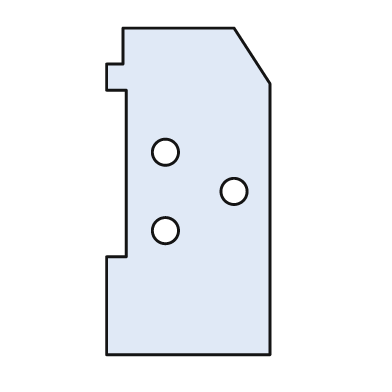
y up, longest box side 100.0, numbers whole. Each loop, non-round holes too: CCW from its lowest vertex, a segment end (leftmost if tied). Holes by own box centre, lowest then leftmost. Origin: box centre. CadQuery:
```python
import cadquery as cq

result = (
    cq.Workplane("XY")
    .moveTo(-25.0, -50.0)
    .lineTo(25.0, -50.0)
    .lineTo(25.0, 33.0)
    .lineTo(14.0, 50.0)
    .lineTo(-20.0, 50.0)
    .lineTo(-20.0, 39.0)
    .lineTo(-25.0, 39.0)
    .lineTo(-25.0, 31.0)
    .lineTo(-19.0, 31.0)
    .lineTo(-19.0, -20.0)
    .lineTo(-25.0, -20.0)
    .close()
    .moveTo(-7.0, -12.0)
    .circle(4.0)
    .moveTo(14.0, 0.0)
    .circle(4.0)
    .moveTo(-7.0, 12.0)
    .circle(4.0)
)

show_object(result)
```